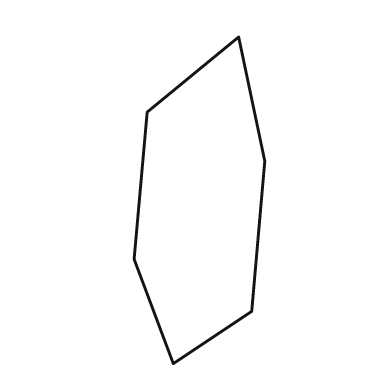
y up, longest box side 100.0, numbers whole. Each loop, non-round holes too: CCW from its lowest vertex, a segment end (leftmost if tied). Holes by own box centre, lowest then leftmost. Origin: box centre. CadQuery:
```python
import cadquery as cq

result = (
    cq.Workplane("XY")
    .moveTo(-8.0, -50.0)
    .lineTo(16.0, -34.0)
    .lineTo(20.0, 12.0)
    .lineTo(12.0, 50.0)
    .lineTo(-16.0, 27.0)
    .lineTo(-20.0, -18.0)
    .close()
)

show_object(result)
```